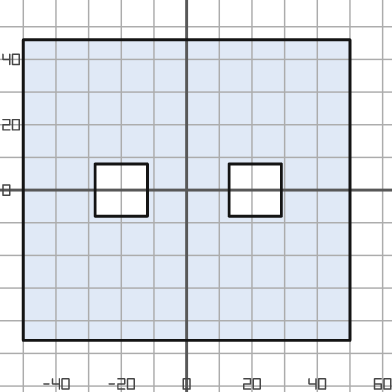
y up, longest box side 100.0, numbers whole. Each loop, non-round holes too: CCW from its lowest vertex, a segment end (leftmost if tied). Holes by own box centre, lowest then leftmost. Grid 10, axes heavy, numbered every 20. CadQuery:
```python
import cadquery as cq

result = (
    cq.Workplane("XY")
    .moveTo(-50.0, -46.0)
    .lineTo(50.0, -46.0)
    .lineTo(50.0, 46.0)
    .lineTo(-50.0, 46.0)
    .close()
    .moveTo(-28.0, -8.0)
    .lineTo(-12.0, -8.0)
    .lineTo(-12.0, 8.0)
    .lineTo(-28.0, 8.0)
    .close()
    .moveTo(13.0, -8.0)
    .lineTo(29.0, -8.0)
    .lineTo(29.0, 8.0)
    .lineTo(13.0, 8.0)
    .close()
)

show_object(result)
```